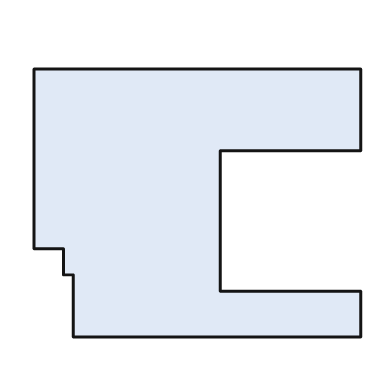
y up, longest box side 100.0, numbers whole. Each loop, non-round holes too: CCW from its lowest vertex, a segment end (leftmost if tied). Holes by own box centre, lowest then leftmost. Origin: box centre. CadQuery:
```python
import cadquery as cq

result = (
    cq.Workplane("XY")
    .moveTo(-38.0, -41.0)
    .lineTo(50.0, -41.0)
    .lineTo(50.0, -27.0)
    .lineTo(7.0, -27.0)
    .lineTo(7.0, 16.0)
    .lineTo(50.0, 16.0)
    .lineTo(50.0, 41.0)
    .lineTo(-50.0, 41.0)
    .lineTo(-50.0, -14.0)
    .lineTo(-41.0, -14.0)
    .lineTo(-41.0, -22.0)
    .lineTo(-38.0, -22.0)
    .close()
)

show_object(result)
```